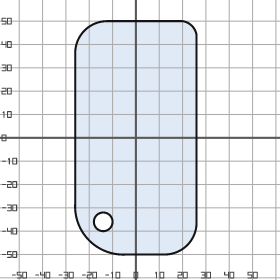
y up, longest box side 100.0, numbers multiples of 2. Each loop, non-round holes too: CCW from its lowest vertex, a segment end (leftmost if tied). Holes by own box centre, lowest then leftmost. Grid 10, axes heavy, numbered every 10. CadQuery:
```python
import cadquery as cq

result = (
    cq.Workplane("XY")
    .moveTo(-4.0, -50.0)
    .lineTo(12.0, -50.0)
    .threePointArc((22.0, -46.0), (26.0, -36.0))
    .lineTo(26.0, 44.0)
    .threePointArc((24.0, 48.0), (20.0, 50.0))
    .lineTo(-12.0, 50.0)
    .threePointArc((-22.0, 46.0), (-26.0, 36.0))
    .lineTo(-26.0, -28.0)
    .threePointArc((-20.0, -44.0), (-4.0, -50.0))
    .close()
    .moveTo(-14.0, -36.0)
    .circle(4.0)
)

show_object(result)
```